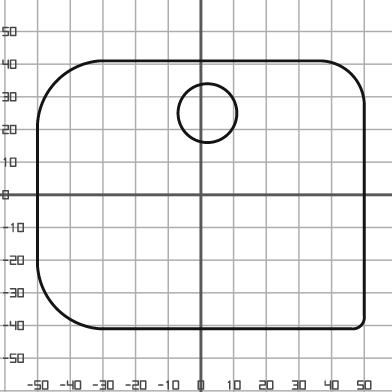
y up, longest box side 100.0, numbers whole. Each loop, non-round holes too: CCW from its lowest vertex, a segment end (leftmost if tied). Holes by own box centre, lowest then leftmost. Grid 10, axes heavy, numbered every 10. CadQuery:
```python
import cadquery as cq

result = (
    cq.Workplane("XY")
    .moveTo(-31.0, -41.0)
    .lineTo(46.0, -41.0)
    .threePointArc((49.0, -40.0), (50.0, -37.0))
    .lineTo(50.0, 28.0)
    .threePointArc((46.0, 37.0), (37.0, 41.0))
    .lineTo(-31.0, 41.0)
    .threePointArc((-44.0, 35.0), (-50.0, 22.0))
    .lineTo(-50.0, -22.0)
    .threePointArc((-44.0, -35.0), (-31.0, -41.0))
    .close()
    .moveTo(2.0, 25.0)
    .circle(9.0)
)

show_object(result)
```